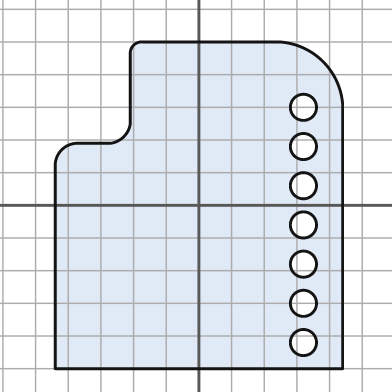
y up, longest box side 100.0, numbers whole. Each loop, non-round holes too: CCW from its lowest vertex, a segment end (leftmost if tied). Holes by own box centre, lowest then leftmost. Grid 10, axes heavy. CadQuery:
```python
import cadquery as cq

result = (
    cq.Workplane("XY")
    .moveTo(-44.0, -50.0)
    .lineTo(44.0, -50.0)
    .lineTo(44.0, 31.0)
    .threePointArc((38.0, 44.0), (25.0, 50.0))
    .lineTo(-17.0, 50.0)
    .threePointArc((-20.0, 49.0), (-21.0, 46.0))
    .lineTo(-21.0, 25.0)
    .threePointArc((-23.0, 21.0), (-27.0, 19.0))
    .lineTo(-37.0, 19.0)
    .threePointArc((-42.0, 17.0), (-44.0, 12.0))
    .close()
    .moveTo(32.0, -42.0)
    .circle(4.0)
    .moveTo(32.0, -30.0)
    .circle(4.0)
    .moveTo(32.0, -18.0)
    .circle(4.0)
    .moveTo(32.0, -6.0)
    .circle(4.0)
    .moveTo(32.0, 6.0)
    .circle(4.0)
    .moveTo(32.0, 18.0)
    .circle(4.0)
    .moveTo(32.0, 30.0)
    .circle(4.0)
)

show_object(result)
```